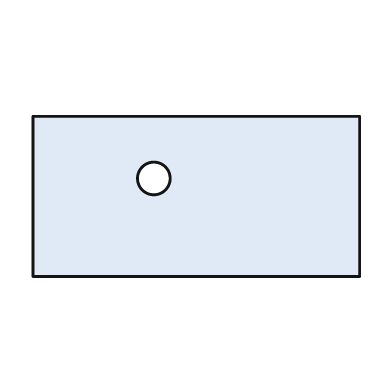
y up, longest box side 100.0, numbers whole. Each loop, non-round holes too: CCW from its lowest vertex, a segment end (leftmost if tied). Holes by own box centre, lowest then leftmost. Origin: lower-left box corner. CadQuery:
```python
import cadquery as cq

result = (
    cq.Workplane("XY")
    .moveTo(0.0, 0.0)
    .lineTo(100.0, 0.0)
    .lineTo(100.0, 49.0)
    .lineTo(0.0, 49.0)
    .close()
    .moveTo(37.0, 30.0)
    .circle(5.0)
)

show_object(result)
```